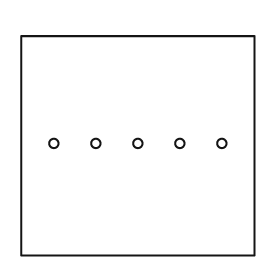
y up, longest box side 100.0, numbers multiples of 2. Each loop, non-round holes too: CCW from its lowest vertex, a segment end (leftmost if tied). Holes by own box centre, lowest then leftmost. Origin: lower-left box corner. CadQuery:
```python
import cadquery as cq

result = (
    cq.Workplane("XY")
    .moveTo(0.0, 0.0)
    .lineTo(100.0, 0.0)
    .lineTo(100.0, 94.0)
    .lineTo(0.0, 94.0)
    .close()
    .moveTo(14.0, 48.0)
    .circle(2.0)
    .moveTo(32.0, 48.0)
    .circle(2.0)
    .moveTo(50.0, 48.0)
    .circle(2.0)
    .moveTo(68.0, 48.0)
    .circle(2.0)
    .moveTo(86.0, 48.0)
    .circle(2.0)
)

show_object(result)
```